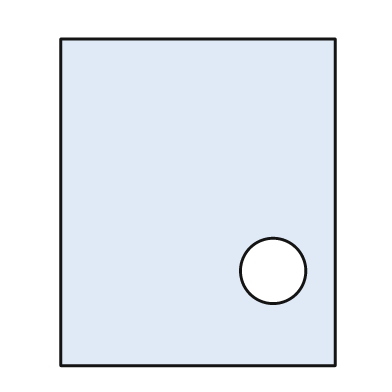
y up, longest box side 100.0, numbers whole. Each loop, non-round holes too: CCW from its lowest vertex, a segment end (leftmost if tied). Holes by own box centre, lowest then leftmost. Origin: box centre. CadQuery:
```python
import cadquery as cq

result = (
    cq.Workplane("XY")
    .moveTo(-42.0, -50.0)
    .lineTo(42.0, -50.0)
    .lineTo(42.0, 50.0)
    .lineTo(-42.0, 50.0)
    .close()
    .moveTo(23.0, -21.0)
    .circle(10.0)
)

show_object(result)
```